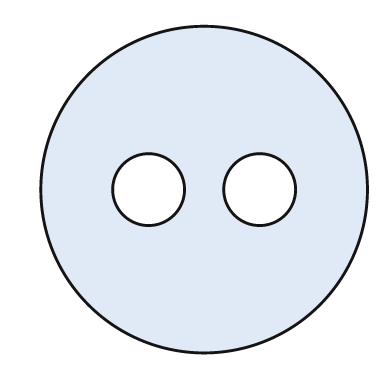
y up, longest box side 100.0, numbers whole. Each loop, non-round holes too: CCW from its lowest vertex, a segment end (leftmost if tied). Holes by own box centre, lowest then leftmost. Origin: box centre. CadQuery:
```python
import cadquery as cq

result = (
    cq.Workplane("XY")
    .moveTo(0.0, 0.0)
    .circle(50.0)
    .moveTo(-17.0, 0.0)
    .circle(11.0)
    .moveTo(17.0, 0.0)
    .circle(11.0)
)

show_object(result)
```